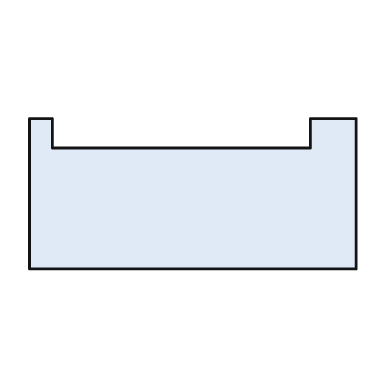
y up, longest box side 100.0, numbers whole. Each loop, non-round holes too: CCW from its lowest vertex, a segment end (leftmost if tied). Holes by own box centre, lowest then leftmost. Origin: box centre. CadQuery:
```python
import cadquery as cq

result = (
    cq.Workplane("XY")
    .moveTo(-50.0, -23.0)
    .lineTo(50.0, -23.0)
    .lineTo(50.0, 23.0)
    .lineTo(36.0, 23.0)
    .lineTo(36.0, 14.0)
    .lineTo(-43.0, 14.0)
    .lineTo(-43.0, 23.0)
    .lineTo(-50.0, 23.0)
    .close()
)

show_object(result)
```